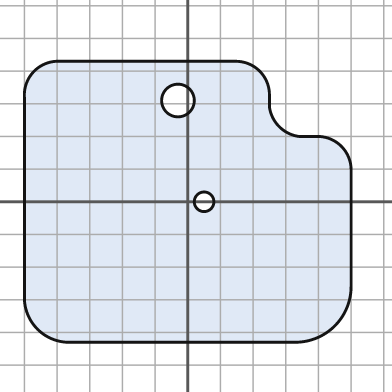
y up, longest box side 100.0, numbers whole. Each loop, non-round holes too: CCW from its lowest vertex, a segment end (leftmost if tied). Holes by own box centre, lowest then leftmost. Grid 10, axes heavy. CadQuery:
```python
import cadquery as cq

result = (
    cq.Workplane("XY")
    .moveTo(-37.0, -43.0)
    .lineTo(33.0, -43.0)
    .threePointArc((45.0, -38.0), (50.0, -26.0))
    .lineTo(50.0, 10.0)
    .threePointArc((47.0, 17.0), (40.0, 20.0))
    .lineTo(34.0, 20.0)
    .threePointArc((28.0, 23.0), (25.0, 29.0))
    .lineTo(25.0, 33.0)
    .threePointArc((22.0, 40.0), (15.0, 43.0))
    .lineTo(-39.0, 43.0)
    .threePointArc((-47.0, 40.0), (-50.0, 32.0))
    .lineTo(-50.0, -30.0)
    .threePointArc((-46.0, -39.0), (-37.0, -43.0))
    .close()
    .moveTo(5.0, 0.0)
    .circle(3.0)
    .moveTo(-3.0, 31.0)
    .circle(5.0)
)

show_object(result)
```